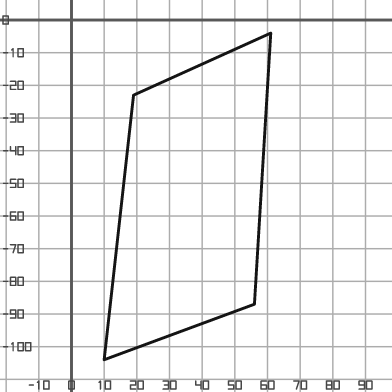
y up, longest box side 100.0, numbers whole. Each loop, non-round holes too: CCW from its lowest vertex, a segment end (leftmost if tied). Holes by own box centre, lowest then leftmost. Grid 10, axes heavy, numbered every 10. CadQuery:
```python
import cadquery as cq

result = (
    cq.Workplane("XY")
    .moveTo(10.0, -104.0)
    .lineTo(56.0, -87.0)
    .lineTo(61.0, -4.0)
    .lineTo(19.0, -23.0)
    .close()
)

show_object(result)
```